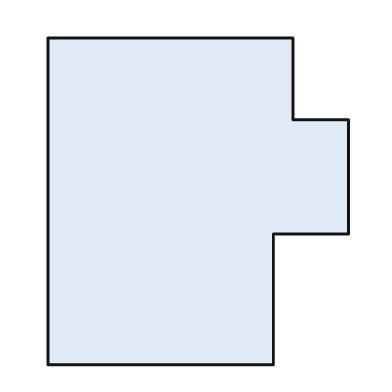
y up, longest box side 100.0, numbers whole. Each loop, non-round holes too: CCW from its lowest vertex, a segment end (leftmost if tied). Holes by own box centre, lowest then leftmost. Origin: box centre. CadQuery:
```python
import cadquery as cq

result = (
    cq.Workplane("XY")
    .moveTo(-46.0, -50.0)
    .lineTo(23.0, -50.0)
    .lineTo(23.0, -10.0)
    .lineTo(46.0, -10.0)
    .lineTo(46.0, 25.0)
    .lineTo(29.0, 25.0)
    .lineTo(29.0, 50.0)
    .lineTo(-46.0, 50.0)
    .close()
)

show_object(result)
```